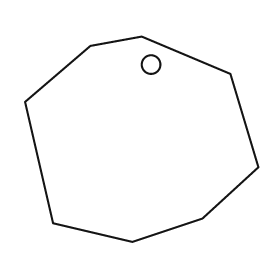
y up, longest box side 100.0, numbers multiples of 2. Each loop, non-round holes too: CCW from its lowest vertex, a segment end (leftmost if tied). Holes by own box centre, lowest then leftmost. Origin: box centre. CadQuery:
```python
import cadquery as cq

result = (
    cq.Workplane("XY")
    .moveTo(-4.0, -44.0)
    .lineTo(26.0, -34.0)
    .lineTo(50.0, -12.0)
    .lineTo(38.0, 28.0)
    .lineTo(0.0, 44.0)
    .lineTo(-22.0, 40.0)
    .lineTo(-50.0, 16.0)
    .lineTo(-38.0, -36.0)
    .close()
    .moveTo(4.0, 32.0)
    .circle(4.0)
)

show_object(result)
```